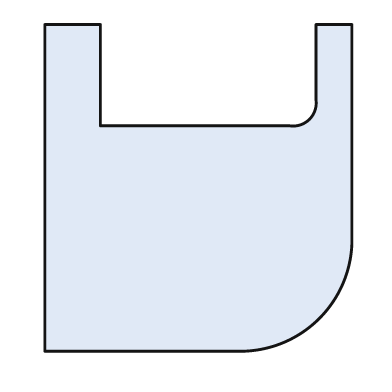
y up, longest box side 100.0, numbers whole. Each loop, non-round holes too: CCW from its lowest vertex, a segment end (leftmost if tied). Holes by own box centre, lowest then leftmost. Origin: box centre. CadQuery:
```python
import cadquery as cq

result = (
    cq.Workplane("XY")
    .moveTo(-47.0, -50.0)
    .lineTo(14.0, -50.0)
    .threePointArc((37.0, -40.0), (47.0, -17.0))
    .lineTo(47.0, 50.0)
    .lineTo(36.0, 50.0)
    .lineTo(36.0, 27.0)
    .threePointArc((34.0, 21.0), (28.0, 19.0))
    .lineTo(-30.0, 19.0)
    .lineTo(-30.0, 50.0)
    .lineTo(-47.0, 50.0)
    .close()
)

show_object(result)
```